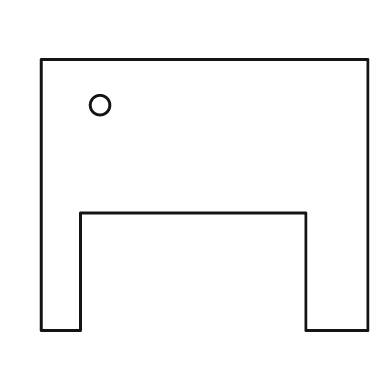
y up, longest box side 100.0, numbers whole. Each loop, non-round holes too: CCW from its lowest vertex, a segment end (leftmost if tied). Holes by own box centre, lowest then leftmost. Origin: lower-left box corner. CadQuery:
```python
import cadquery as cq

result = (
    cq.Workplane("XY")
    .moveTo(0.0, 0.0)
    .lineTo(12.0, 0.0)
    .lineTo(12.0, 36.0)
    .lineTo(81.0, 36.0)
    .lineTo(81.0, 0.0)
    .lineTo(100.0, 0.0)
    .lineTo(100.0, 83.0)
    .lineTo(0.0, 83.0)
    .close()
    .moveTo(18.0, 69.0)
    .circle(3.0)
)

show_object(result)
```